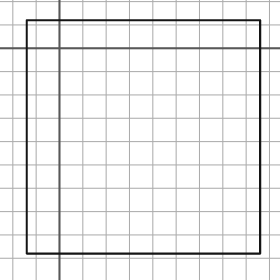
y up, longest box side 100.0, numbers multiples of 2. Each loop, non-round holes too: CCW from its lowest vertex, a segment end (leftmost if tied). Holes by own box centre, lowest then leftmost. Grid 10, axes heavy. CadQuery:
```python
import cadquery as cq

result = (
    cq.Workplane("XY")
    .moveTo(-14.0, -88.0)
    .lineTo(86.0, -88.0)
    .lineTo(86.0, 12.0)
    .lineTo(-14.0, 12.0)
    .close()
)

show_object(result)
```